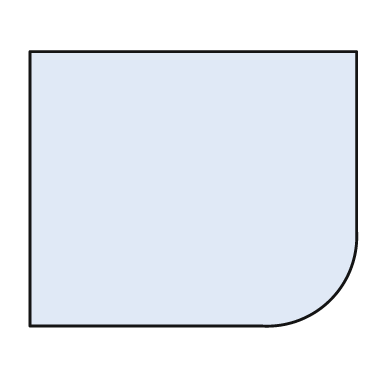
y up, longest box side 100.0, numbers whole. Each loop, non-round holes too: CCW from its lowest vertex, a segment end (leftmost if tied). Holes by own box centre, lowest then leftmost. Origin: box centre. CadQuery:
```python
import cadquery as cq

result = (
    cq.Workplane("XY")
    .moveTo(-50.0, -42.0)
    .lineTo(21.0, -42.0)
    .threePointArc((42.0, -34.0), (50.0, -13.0))
    .lineTo(50.0, 42.0)
    .lineTo(-50.0, 42.0)
    .close()
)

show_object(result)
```